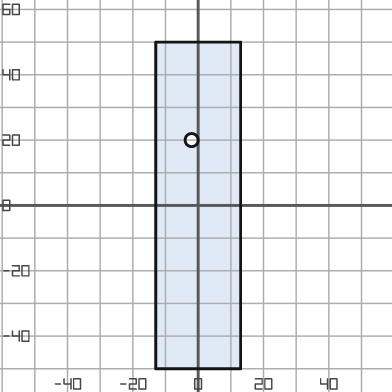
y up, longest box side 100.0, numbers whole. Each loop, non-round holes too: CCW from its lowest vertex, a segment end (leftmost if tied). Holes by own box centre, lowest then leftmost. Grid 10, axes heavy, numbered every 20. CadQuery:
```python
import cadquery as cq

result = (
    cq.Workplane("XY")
    .moveTo(-13.0, -50.0)
    .lineTo(13.0, -50.0)
    .lineTo(13.0, 50.0)
    .lineTo(-13.0, 50.0)
    .close()
    .moveTo(-2.0, 20.0)
    .circle(2.0)
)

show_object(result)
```